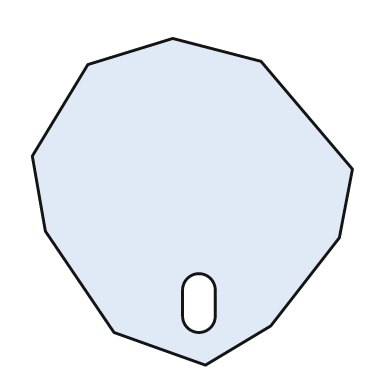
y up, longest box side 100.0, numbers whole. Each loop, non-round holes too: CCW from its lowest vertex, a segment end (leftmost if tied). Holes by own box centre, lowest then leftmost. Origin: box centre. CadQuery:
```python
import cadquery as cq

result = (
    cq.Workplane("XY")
    .moveTo(4.0, -50.0)
    .lineTo(24.0, -38.0)
    .lineTo(45.0, -11.0)
    .lineTo(49.0, 10.0)
    .lineTo(21.0, 43.0)
    .lineTo(-6.0, 50.0)
    .lineTo(-32.0, 42.0)
    .lineTo(-49.0, 14.0)
    .lineTo(-45.0, -9.0)
    .lineTo(-24.0, -40.0)
    .close()
    .moveTo(-3.0, -35.0)
    .threePointArc((2.0, -40.0), (7.0, -35.0))
    .lineTo(7.0, -27.0)
    .threePointArc((2.0, -22.0), (-3.0, -27.0))
    .close()
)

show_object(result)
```